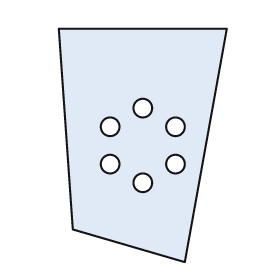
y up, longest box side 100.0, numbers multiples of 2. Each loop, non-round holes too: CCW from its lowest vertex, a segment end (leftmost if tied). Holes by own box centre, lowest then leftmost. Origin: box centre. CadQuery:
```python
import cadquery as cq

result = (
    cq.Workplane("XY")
    .moveTo(18.0, -50.0)
    .lineTo(36.0, 50.0)
    .lineTo(-36.0, 50.0)
    .lineTo(-30.0, -36.0)
    .close()
    .moveTo(0.0, -16.0)
    .circle(4.0)
    .moveTo(-14.0, -8.0)
    .circle(4.0)
    .moveTo(14.0, -8.0)
    .circle(4.0)
    .moveTo(-14.0, 8.0)
    .circle(4.0)
    .moveTo(14.0, 8.0)
    .circle(4.0)
    .moveTo(0.0, 16.0)
    .circle(4.0)
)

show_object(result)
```